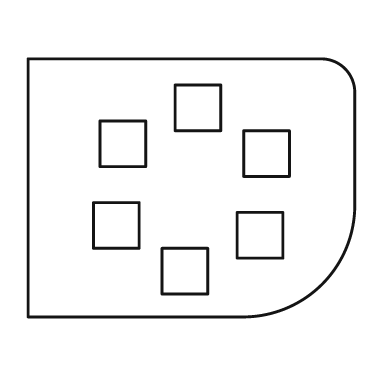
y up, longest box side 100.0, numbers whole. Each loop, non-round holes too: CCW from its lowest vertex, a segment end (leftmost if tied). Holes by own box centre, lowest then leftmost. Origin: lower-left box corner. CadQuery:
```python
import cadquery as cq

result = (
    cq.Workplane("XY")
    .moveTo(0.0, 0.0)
    .lineTo(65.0, 0.0)
    .threePointArc((90.0, 10.0), (100.0, 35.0))
    .lineTo(100.0, 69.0)
    .threePointArc((97.0, 76.0), (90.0, 79.0))
    .lineTo(0.0, 79.0)
    .close()
    .moveTo(41.0, 7.0)
    .lineTo(55.0, 7.0)
    .lineTo(55.0, 21.0)
    .lineTo(41.0, 21.0)
    .close()
    .moveTo(64.0, 18.0)
    .lineTo(78.0, 18.0)
    .lineTo(78.0, 32.0)
    .lineTo(64.0, 32.0)
    .close()
    .moveTo(20.0, 21.0)
    .lineTo(34.0, 21.0)
    .lineTo(34.0, 35.0)
    .lineTo(20.0, 35.0)
    .close()
    .moveTo(66.0, 43.0)
    .lineTo(80.0, 43.0)
    .lineTo(80.0, 57.0)
    .lineTo(66.0, 57.0)
    .close()
    .moveTo(22.0, 46.0)
    .lineTo(36.0, 46.0)
    .lineTo(36.0, 60.0)
    .lineTo(22.0, 60.0)
    .close()
    .moveTo(45.0, 57.0)
    .lineTo(59.0, 57.0)
    .lineTo(59.0, 71.0)
    .lineTo(45.0, 71.0)
    .close()
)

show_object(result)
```